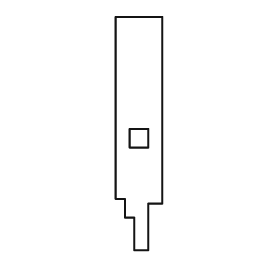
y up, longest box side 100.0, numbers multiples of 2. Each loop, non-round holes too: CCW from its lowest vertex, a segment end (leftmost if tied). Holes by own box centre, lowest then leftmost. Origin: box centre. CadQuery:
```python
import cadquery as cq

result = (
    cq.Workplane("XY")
    .moveTo(-2.0, -50.0)
    .lineTo(4.0, -50.0)
    .lineTo(4.0, -30.0)
    .lineTo(10.0, -30.0)
    .lineTo(10.0, 50.0)
    .lineTo(-10.0, 50.0)
    .lineTo(-10.0, -28.0)
    .lineTo(-6.0, -28.0)
    .lineTo(-6.0, -36.0)
    .lineTo(-2.0, -36.0)
    .close()
    .moveTo(-4.0, -6.0)
    .lineTo(4.0, -6.0)
    .lineTo(4.0, 2.0)
    .lineTo(-4.0, 2.0)
    .close()
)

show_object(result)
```